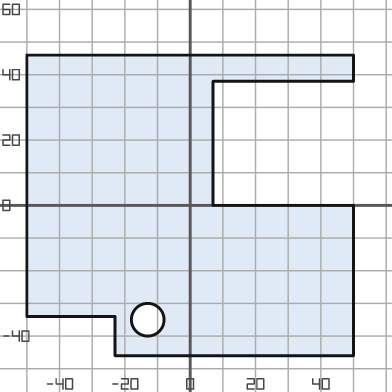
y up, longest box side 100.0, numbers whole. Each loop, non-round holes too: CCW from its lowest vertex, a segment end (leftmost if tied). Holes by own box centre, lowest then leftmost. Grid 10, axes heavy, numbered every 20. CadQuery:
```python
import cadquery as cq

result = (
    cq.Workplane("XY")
    .moveTo(-23.0, -46.0)
    .lineTo(50.0, -46.0)
    .lineTo(50.0, 0.0)
    .lineTo(7.0, 0.0)
    .lineTo(7.0, 38.0)
    .lineTo(50.0, 38.0)
    .lineTo(50.0, 46.0)
    .lineTo(-50.0, 46.0)
    .lineTo(-50.0, -34.0)
    .lineTo(-23.0, -34.0)
    .close()
    .moveTo(-13.0, -35.0)
    .circle(5.0)
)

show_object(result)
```